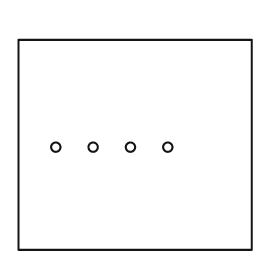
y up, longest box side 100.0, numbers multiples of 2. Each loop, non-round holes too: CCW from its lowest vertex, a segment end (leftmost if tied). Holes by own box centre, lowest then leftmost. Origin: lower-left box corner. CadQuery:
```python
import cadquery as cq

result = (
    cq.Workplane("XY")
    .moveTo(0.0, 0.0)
    .lineTo(100.0, 0.0)
    .lineTo(100.0, 90.0)
    .lineTo(0.0, 90.0)
    .close()
    .moveTo(16.0, 44.0)
    .circle(2.0)
    .moveTo(32.0, 44.0)
    .circle(2.0)
    .moveTo(48.0, 44.0)
    .circle(2.0)
    .moveTo(64.0, 44.0)
    .circle(2.0)
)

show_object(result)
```